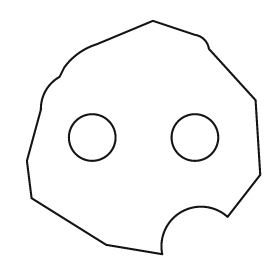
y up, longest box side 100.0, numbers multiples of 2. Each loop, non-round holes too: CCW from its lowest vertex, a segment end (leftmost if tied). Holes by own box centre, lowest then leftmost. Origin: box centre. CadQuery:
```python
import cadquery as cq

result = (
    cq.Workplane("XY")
    .moveTo(8.0, -50.0)
    .threePointArc((16.0, -32.0), (36.0, -34.0))
    .lineTo(50.0, -16.0)
    .lineTo(48.0, 16.0)
    .lineTo(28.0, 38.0)
    .threePointArc((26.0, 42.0), (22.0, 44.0))
    .lineTo(4.0, 50.0)
    .lineTo(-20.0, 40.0)
    .threePointArc((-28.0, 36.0), (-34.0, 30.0))
    .lineTo(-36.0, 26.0)
    .threePointArc((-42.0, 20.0), (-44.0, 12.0))
    .lineTo(-50.0, -10.0)
    .lineTo(-48.0, -26.0)
    .lineTo(-16.0, -46.0)
    .close()
    .moveTo(-22.0, 0.0)
    .circle(10.0)
    .moveTo(22.0, 0.0)
    .circle(10.0)
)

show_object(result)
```